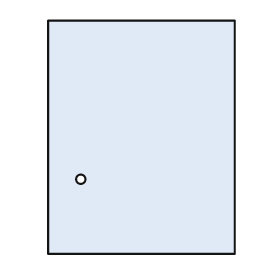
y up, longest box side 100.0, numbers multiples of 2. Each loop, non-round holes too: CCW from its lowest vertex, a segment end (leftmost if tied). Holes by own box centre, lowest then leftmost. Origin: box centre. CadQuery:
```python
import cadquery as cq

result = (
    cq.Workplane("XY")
    .moveTo(-40.0, -50.0)
    .lineTo(40.0, -50.0)
    .lineTo(40.0, 50.0)
    .lineTo(-40.0, 50.0)
    .close()
    .moveTo(-26.0, -18.0)
    .circle(2.0)
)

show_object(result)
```